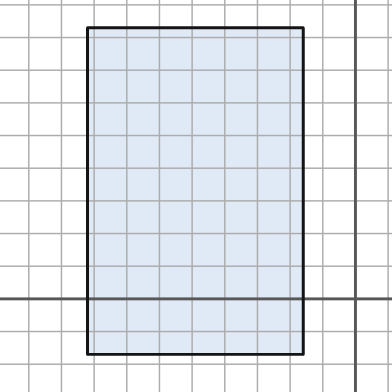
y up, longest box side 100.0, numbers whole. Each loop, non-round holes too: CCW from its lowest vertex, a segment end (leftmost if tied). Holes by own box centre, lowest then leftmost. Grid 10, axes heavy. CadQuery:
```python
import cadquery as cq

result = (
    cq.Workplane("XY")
    .moveTo(-82.0, -17.0)
    .lineTo(-16.0, -17.0)
    .lineTo(-16.0, 83.0)
    .lineTo(-82.0, 83.0)
    .close()
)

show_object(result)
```